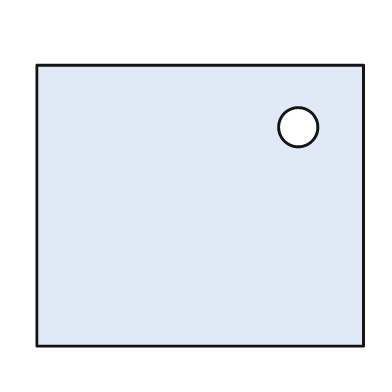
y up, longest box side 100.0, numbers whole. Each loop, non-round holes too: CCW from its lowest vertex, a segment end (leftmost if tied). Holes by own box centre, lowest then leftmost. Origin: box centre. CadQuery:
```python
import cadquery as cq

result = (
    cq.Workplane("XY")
    .moveTo(-50.0, -43.0)
    .lineTo(50.0, -43.0)
    .lineTo(50.0, 43.0)
    .lineTo(-50.0, 43.0)
    .close()
    .moveTo(30.0, 24.0)
    .circle(6.0)
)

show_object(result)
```